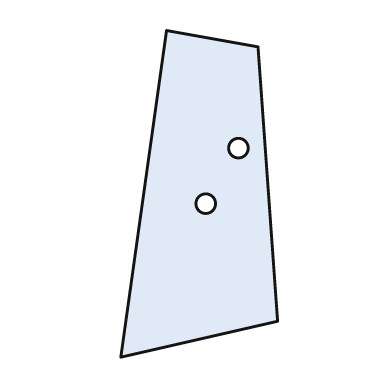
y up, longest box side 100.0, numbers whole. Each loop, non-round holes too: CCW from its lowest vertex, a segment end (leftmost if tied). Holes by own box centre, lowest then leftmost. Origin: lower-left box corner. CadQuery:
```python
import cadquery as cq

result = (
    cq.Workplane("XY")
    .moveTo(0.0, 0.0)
    .lineTo(48.0, 11.0)
    .lineTo(42.0, 95.0)
    .lineTo(14.0, 100.0)
    .close()
    .moveTo(26.0, 47.0)
    .circle(3.0)
    .moveTo(36.0, 64.0)
    .circle(3.0)
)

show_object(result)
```